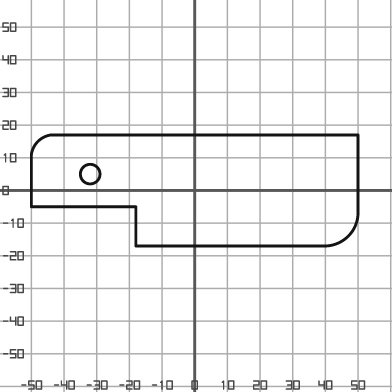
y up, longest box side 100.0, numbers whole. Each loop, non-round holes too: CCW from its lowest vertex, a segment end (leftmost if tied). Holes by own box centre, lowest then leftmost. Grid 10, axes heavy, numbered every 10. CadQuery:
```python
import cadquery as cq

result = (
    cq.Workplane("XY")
    .moveTo(-18.0, -17.0)
    .lineTo(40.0, -17.0)
    .threePointArc((47.0, -14.0), (50.0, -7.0))
    .lineTo(50.0, 17.0)
    .lineTo(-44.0, 17.0)
    .threePointArc((-48.0, 15.0), (-50.0, 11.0))
    .lineTo(-50.0, -5.0)
    .lineTo(-18.0, -5.0)
    .close()
    .moveTo(-32.0, 5.0)
    .circle(3.0)
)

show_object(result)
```